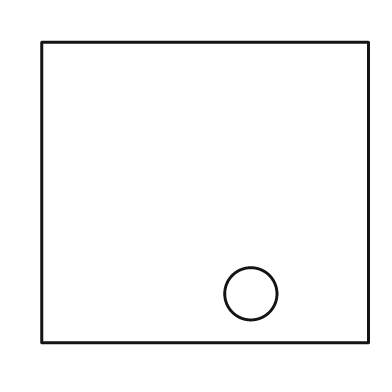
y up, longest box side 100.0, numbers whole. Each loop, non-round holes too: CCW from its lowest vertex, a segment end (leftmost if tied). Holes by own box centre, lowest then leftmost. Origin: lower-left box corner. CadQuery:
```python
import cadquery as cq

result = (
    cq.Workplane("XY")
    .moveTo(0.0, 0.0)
    .lineTo(100.0, 0.0)
    .lineTo(100.0, 92.0)
    .lineTo(0.0, 92.0)
    .close()
    .moveTo(64.0, 15.0)
    .circle(8.0)
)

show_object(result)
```